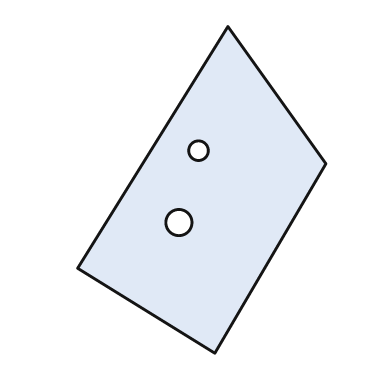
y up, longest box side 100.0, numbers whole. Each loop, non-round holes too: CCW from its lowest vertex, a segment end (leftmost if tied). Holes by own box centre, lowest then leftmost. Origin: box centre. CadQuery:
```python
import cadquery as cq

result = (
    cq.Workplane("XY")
    .moveTo(4.0, -50.0)
    .lineTo(38.0, 8.0)
    .lineTo(8.0, 50.0)
    .lineTo(-38.0, -24.0)
    .close()
    .moveTo(-7.0, -10.0)
    .circle(4.0)
    .moveTo(-1.0, 12.0)
    .circle(3.0)
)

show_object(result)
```